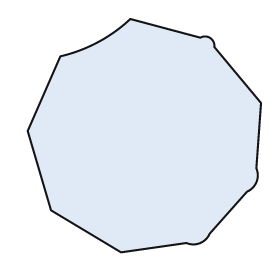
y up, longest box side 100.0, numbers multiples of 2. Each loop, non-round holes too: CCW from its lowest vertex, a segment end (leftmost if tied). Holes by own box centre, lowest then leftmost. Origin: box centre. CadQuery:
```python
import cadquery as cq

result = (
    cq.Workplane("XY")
    .moveTo(-10.0, -50.0)
    .lineTo(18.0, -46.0)
    .threePointArc((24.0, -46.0), (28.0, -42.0))
    .lineTo(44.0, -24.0)
    .threePointArc((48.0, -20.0), (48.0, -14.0))
    .lineTo(50.0, 14.0)
    .lineTo(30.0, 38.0)
    .threePointArc((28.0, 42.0), (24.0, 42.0))
    .lineTo(-6.0, 50.0)
    .threePointArc((-20.0, 40.0), (-36.0, 34.0))
    .lineTo(-50.0, 2.0)
    .lineTo(-40.0, -32.0)
    .close()
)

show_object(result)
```